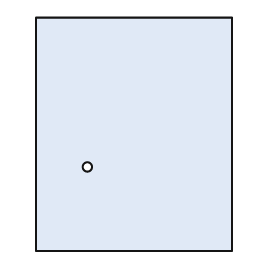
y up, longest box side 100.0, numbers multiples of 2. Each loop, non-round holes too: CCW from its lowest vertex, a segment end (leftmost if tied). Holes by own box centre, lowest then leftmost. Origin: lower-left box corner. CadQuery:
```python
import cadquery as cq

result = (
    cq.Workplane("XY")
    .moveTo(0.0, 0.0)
    .lineTo(84.0, 0.0)
    .lineTo(84.0, 100.0)
    .lineTo(0.0, 100.0)
    .close()
    .moveTo(22.0, 36.0)
    .circle(2.0)
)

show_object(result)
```